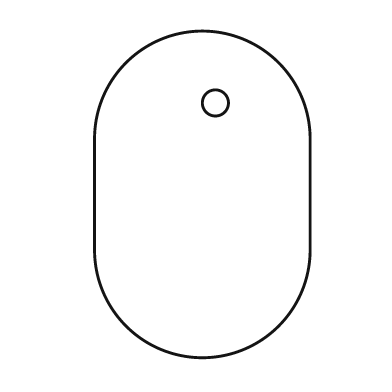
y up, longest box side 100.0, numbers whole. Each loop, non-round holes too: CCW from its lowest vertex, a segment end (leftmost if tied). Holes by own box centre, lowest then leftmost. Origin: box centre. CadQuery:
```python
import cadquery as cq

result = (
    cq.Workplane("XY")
    .moveTo(-33.0, -17.0)
    .threePointArc((0.0, -50.0), (33.0, -17.0))
    .lineTo(33.0, 17.0)
    .threePointArc((0.0, 50.0), (-33.0, 17.0))
    .close()
    .moveTo(4.0, 28.0)
    .circle(4.0)
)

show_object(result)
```